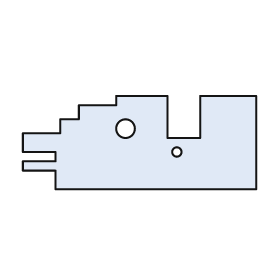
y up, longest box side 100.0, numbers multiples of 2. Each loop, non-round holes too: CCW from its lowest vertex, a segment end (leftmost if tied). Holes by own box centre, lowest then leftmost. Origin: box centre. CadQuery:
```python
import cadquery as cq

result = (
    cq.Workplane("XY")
    .moveTo(-36.0, -20.0)
    .lineTo(50.0, -20.0)
    .lineTo(50.0, 20.0)
    .lineTo(26.0, 20.0)
    .lineTo(26.0, 2.0)
    .lineTo(12.0, 2.0)
    .lineTo(12.0, 20.0)
    .lineTo(-10.0, 20.0)
    .lineTo(-10.0, 16.0)
    .lineTo(-26.0, 16.0)
    .lineTo(-26.0, 10.0)
    .lineTo(-34.0, 10.0)
    .lineTo(-34.0, 4.0)
    .lineTo(-50.0, 4.0)
    .lineTo(-50.0, -4.0)
    .lineTo(-36.0, -4.0)
    .lineTo(-36.0, -8.0)
    .lineTo(-50.0, -8.0)
    .lineTo(-50.0, -12.0)
    .lineTo(-36.0, -12.0)
    .close()
    .moveTo(16.0, -4.0)
    .circle(2.0)
    .moveTo(-6.0, 6.0)
    .circle(4.0)
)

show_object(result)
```